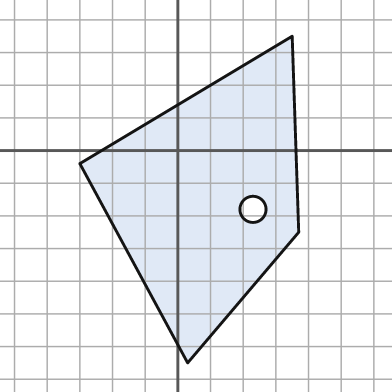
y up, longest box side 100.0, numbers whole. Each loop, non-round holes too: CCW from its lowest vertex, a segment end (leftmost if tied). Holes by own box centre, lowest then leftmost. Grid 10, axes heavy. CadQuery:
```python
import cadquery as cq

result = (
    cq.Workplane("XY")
    .moveTo(3.0, -65.0)
    .lineTo(37.0, -25.0)
    .lineTo(35.0, 35.0)
    .lineTo(-30.0, -4.0)
    .close()
    .moveTo(23.0, -18.0)
    .circle(4.0)
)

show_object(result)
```